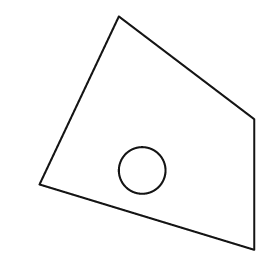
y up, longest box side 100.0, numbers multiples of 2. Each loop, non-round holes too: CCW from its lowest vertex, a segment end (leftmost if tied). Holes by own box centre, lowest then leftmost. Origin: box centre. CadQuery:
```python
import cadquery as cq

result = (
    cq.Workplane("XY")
    .moveTo(46.0, -50.0)
    .lineTo(46.0, 6.0)
    .lineTo(-12.0, 50.0)
    .lineTo(-46.0, -22.0)
    .close()
    .moveTo(-2.0, -16.0)
    .circle(10.0)
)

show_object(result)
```